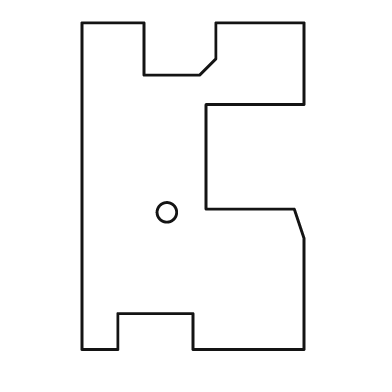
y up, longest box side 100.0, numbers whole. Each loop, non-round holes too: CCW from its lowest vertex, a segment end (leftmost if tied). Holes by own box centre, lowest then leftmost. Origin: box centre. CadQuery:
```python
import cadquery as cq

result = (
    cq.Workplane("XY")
    .moveTo(-34.0, -50.0)
    .lineTo(-23.0, -50.0)
    .lineTo(-23.0, -39.0)
    .lineTo(0.0, -39.0)
    .lineTo(0.0, -50.0)
    .lineTo(34.0, -50.0)
    .lineTo(34.0, -16.0)
    .lineTo(31.0, -7.0)
    .lineTo(4.0, -7.0)
    .lineTo(4.0, 25.0)
    .lineTo(34.0, 25.0)
    .lineTo(34.0, 50.0)
    .lineTo(7.0, 50.0)
    .lineTo(7.0, 39.0)
    .lineTo(2.0, 34.0)
    .lineTo(-15.0, 34.0)
    .lineTo(-15.0, 50.0)
    .lineTo(-34.0, 50.0)
    .close()
    .moveTo(-8.0, -8.0)
    .circle(3.0)
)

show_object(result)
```